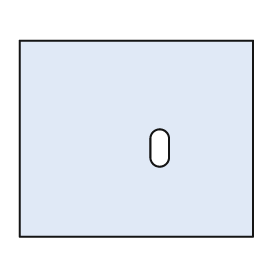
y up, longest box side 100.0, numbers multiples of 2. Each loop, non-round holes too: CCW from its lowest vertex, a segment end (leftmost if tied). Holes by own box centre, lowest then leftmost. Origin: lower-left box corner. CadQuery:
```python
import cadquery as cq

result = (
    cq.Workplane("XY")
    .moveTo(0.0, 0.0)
    .lineTo(100.0, 0.0)
    .lineTo(100.0, 84.0)
    .lineTo(0.0, 84.0)
    .close()
    .moveTo(56.0, 34.0)
    .threePointArc((60.0, 30.0), (64.0, 34.0))
    .lineTo(64.0, 42.0)
    .threePointArc((60.0, 46.0), (56.0, 42.0))
    .close()
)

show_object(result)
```